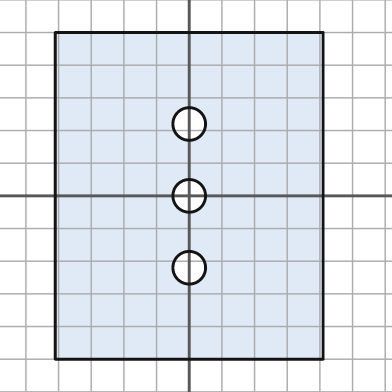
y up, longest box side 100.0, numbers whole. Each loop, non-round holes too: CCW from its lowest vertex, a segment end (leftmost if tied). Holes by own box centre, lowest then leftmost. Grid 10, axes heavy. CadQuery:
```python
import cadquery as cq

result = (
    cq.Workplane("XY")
    .moveTo(-41.0, -50.0)
    .lineTo(41.0, -50.0)
    .lineTo(41.0, 50.0)
    .lineTo(-41.0, 50.0)
    .close()
    .moveTo(0.0, -22.0)
    .circle(5.0)
    .moveTo(0.0, 0.0)
    .circle(5.0)
    .moveTo(0.0, 22.0)
    .circle(5.0)
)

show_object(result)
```